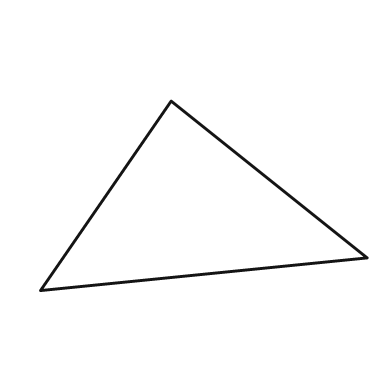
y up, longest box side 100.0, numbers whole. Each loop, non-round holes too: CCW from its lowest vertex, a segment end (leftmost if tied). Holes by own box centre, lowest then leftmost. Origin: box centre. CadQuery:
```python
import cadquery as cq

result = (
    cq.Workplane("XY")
    .moveTo(-50.0, -29.0)
    .lineTo(50.0, -19.0)
    .lineTo(-10.0, 29.0)
    .close()
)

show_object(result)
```